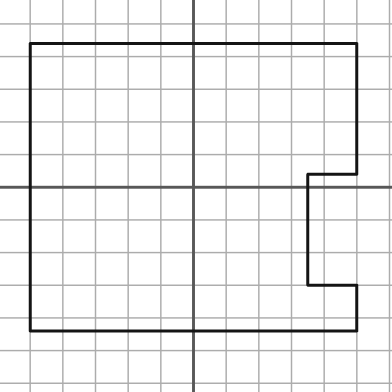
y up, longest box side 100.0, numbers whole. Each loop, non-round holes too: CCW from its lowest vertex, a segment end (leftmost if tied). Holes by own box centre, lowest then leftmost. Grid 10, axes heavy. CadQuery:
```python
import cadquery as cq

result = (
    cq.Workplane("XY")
    .moveTo(-50.0, -44.0)
    .lineTo(50.0, -44.0)
    .lineTo(50.0, -30.0)
    .lineTo(35.0, -30.0)
    .lineTo(35.0, 4.0)
    .lineTo(50.0, 4.0)
    .lineTo(50.0, 44.0)
    .lineTo(-50.0, 44.0)
    .close()
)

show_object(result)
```